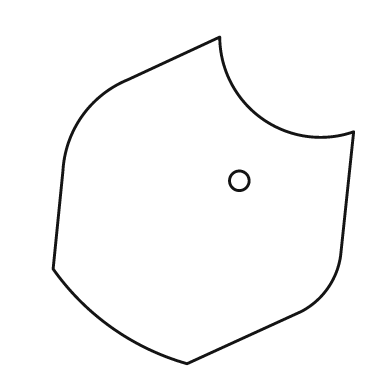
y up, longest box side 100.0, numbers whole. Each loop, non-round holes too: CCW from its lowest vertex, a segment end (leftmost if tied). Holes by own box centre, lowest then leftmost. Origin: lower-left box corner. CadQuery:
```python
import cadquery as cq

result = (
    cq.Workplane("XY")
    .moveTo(41.0, 0.0)
    .lineTo(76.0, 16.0)
    .threePointArc((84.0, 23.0), (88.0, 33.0))
    .lineTo(92.0, 71.0)
    .threePointArc((64.0, 75.0), (51.0, 100.0))
    .lineTo(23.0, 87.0)
    .threePointArc((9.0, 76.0), (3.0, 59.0))
    .lineTo(0.0, 29.0)
    .threePointArc((18.0, 11.0), (41.0, 0.0))
    .close()
    .moveTo(57.0, 56.0)
    .circle(3.0)
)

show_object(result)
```